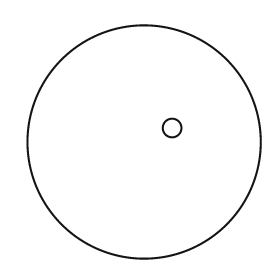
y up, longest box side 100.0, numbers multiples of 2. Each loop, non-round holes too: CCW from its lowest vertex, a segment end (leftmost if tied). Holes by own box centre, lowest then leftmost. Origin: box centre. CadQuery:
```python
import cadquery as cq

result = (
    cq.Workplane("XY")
    .moveTo(0.0, 0.0)
    .circle(50.0)
    .moveTo(12.0, 6.0)
    .circle(4.0)
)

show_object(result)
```